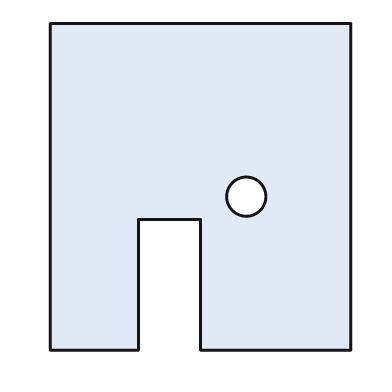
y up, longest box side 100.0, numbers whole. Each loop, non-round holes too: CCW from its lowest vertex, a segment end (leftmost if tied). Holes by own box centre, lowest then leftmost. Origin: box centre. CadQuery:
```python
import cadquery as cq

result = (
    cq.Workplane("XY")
    .moveTo(-46.0, -50.0)
    .lineTo(-19.0, -50.0)
    .lineTo(-19.0, -10.0)
    .lineTo(0.0, -10.0)
    .lineTo(0.0, -50.0)
    .lineTo(46.0, -50.0)
    .lineTo(46.0, 50.0)
    .lineTo(-46.0, 50.0)
    .close()
    .moveTo(14.0, -3.0)
    .circle(6.0)
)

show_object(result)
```